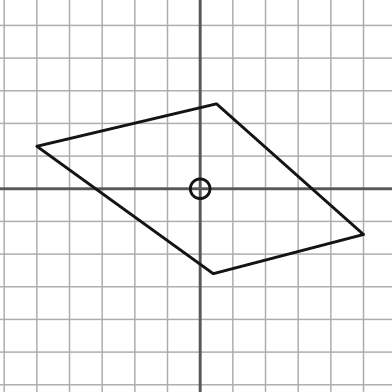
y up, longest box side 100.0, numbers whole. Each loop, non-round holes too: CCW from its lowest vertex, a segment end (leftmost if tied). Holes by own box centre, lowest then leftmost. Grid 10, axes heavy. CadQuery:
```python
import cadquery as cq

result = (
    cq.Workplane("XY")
    .moveTo(4.0, -26.0)
    .lineTo(50.0, -14.0)
    .lineTo(5.0, 26.0)
    .lineTo(-50.0, 13.0)
    .close()
    .moveTo(0.0, 0.0)
    .circle(3.0)
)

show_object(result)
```